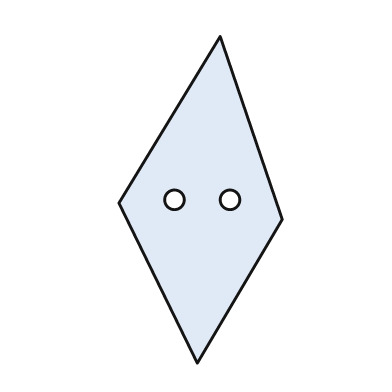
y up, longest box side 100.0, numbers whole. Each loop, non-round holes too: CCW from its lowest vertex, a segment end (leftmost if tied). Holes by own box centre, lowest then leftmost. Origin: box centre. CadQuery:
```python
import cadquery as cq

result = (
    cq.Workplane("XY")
    .moveTo(-1.0, -50.0)
    .lineTo(25.0, -6.0)
    .lineTo(6.0, 50.0)
    .lineTo(-25.0, -1.0)
    .close()
    .moveTo(-8.0, 0.0)
    .circle(3.0)
    .moveTo(9.0, 0.0)
    .circle(3.0)
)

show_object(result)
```